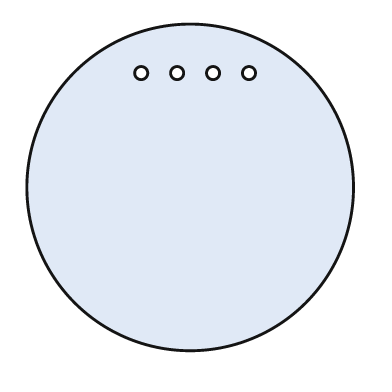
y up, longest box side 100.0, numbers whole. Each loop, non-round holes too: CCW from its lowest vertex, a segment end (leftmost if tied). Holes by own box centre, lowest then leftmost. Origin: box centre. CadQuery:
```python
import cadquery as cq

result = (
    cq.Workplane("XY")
    .moveTo(0.0, 0.0)
    .circle(50.0)
    .moveTo(-15.0, 35.0)
    .circle(2.0)
    .moveTo(-4.0, 35.0)
    .circle(2.0)
    .moveTo(7.0, 35.0)
    .circle(2.0)
    .moveTo(18.0, 35.0)
    .circle(2.0)
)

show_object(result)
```